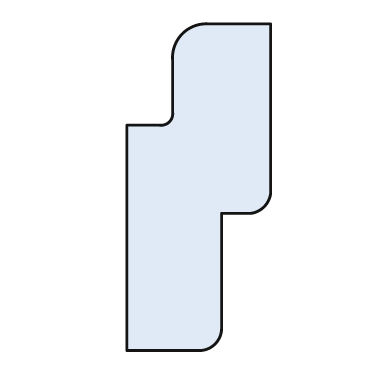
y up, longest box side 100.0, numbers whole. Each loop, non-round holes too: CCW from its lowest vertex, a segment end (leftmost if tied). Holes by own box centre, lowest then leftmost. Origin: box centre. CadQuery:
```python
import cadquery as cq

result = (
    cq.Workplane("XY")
    .moveTo(-22.0, -50.0)
    .lineTo(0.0, -50.0)
    .threePointArc((5.0, -48.0), (7.0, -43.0))
    .lineTo(7.0, -8.0)
    .lineTo(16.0, -8.0)
    .threePointArc((20.0, -6.0), (22.0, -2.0))
    .lineTo(22.0, 50.0)
    .lineTo(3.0, 50.0)
    .threePointArc((-5.0, 47.0), (-8.0, 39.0))
    .lineTo(-8.0, 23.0)
    .threePointArc((-9.0, 20.0), (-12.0, 19.0))
    .lineTo(-22.0, 19.0)
    .close()
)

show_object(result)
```